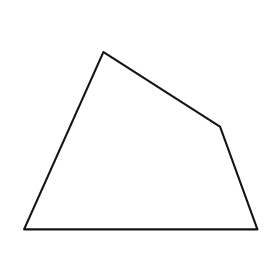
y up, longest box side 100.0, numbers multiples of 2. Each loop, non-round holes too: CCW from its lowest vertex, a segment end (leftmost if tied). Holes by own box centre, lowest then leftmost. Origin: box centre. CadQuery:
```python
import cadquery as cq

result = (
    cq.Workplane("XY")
    .moveTo(-50.0, -38.0)
    .lineTo(50.0, -38.0)
    .lineTo(34.0, 6.0)
    .lineTo(-16.0, 38.0)
    .close()
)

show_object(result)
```